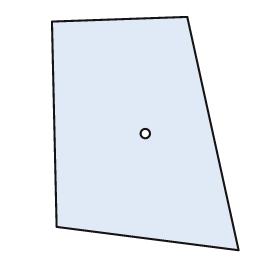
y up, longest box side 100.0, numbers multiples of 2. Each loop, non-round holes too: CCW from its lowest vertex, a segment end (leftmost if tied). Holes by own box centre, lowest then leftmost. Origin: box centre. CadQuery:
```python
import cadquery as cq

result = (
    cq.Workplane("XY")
    .moveTo(40.0, -50.0)
    .lineTo(18.0, 50.0)
    .lineTo(-40.0, 48.0)
    .lineTo(-38.0, -40.0)
    .close()
    .moveTo(0.0, 0.0)
    .circle(2.0)
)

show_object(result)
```